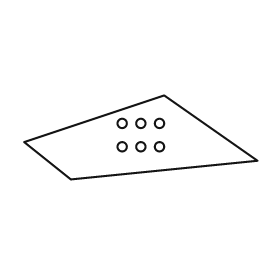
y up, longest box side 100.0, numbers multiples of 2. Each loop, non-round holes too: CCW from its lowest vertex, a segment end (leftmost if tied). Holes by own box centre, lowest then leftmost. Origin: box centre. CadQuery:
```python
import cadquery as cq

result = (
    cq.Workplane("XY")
    .moveTo(-30.0, -18.0)
    .lineTo(50.0, -10.0)
    .lineTo(10.0, 18.0)
    .lineTo(-50.0, -2.0)
    .close()
    .moveTo(-8.0, -4.0)
    .circle(2.0)
    .moveTo(0.0, -4.0)
    .circle(2.0)
    .moveTo(8.0, -4.0)
    .circle(2.0)
    .moveTo(-8.0, 6.0)
    .circle(2.0)
    .moveTo(0.0, 6.0)
    .circle(2.0)
    .moveTo(8.0, 6.0)
    .circle(2.0)
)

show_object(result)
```